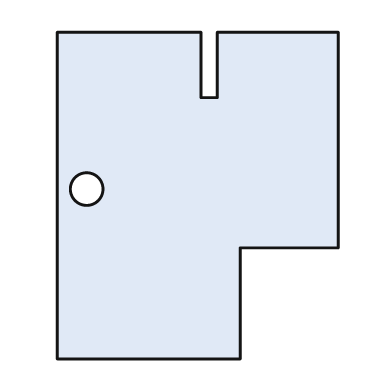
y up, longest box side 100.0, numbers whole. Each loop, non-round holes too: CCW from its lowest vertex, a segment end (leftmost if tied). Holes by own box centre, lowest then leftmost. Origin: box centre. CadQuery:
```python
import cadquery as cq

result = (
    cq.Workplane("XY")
    .moveTo(-43.0, -50.0)
    .lineTo(13.0, -50.0)
    .lineTo(13.0, -16.0)
    .lineTo(43.0, -16.0)
    .lineTo(43.0, 50.0)
    .lineTo(6.0, 50.0)
    .lineTo(6.0, 30.0)
    .lineTo(1.0, 30.0)
    .lineTo(1.0, 50.0)
    .lineTo(-43.0, 50.0)
    .close()
    .moveTo(-34.0, 2.0)
    .circle(5.0)
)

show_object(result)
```